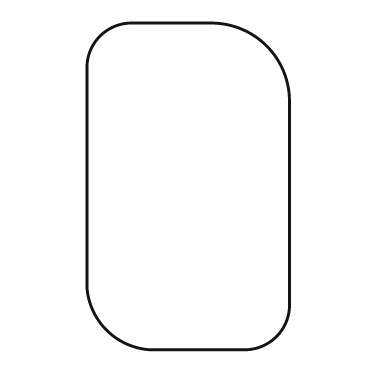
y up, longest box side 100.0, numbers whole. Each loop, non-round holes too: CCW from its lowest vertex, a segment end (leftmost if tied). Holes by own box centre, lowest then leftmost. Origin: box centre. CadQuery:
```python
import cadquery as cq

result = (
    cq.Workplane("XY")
    .moveTo(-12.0, -50.0)
    .lineTo(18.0, -50.0)
    .threePointArc((27.0, -46.0), (31.0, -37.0))
    .lineTo(31.0, 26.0)
    .threePointArc((24.0, 43.0), (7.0, 50.0))
    .lineTo(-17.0, 50.0)
    .threePointArc((-27.0, 46.0), (-31.0, 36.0))
    .lineTo(-31.0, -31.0)
    .threePointArc((-25.0, -44.0), (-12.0, -50.0))
    .close()
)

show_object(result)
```